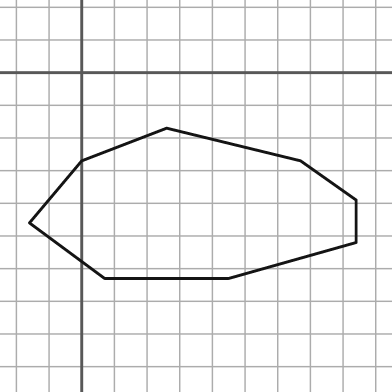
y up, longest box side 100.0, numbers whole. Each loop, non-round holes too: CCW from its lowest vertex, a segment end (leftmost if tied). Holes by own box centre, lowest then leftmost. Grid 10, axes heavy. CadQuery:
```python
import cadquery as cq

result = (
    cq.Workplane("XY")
    .moveTo(7.0, -63.0)
    .lineTo(45.0, -63.0)
    .lineTo(84.0, -52.0)
    .lineTo(84.0, -39.0)
    .lineTo(67.0, -27.0)
    .lineTo(26.0, -17.0)
    .lineTo(0.0, -27.0)
    .lineTo(-16.0, -46.0)
    .close()
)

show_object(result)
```